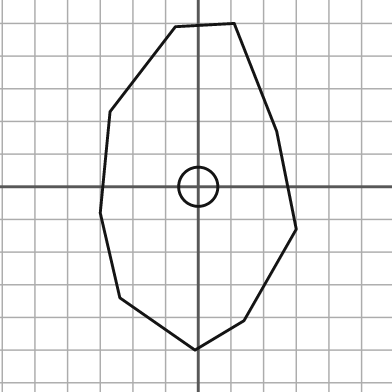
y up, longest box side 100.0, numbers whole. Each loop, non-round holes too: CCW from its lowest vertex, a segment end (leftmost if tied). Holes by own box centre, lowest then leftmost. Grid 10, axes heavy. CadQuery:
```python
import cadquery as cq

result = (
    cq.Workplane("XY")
    .moveTo(-1.0, -50.0)
    .lineTo(14.0, -41.0)
    .lineTo(30.0, -13.0)
    .lineTo(24.0, 17.0)
    .lineTo(11.0, 50.0)
    .lineTo(-7.0, 49.0)
    .lineTo(-27.0, 23.0)
    .lineTo(-30.0, -8.0)
    .lineTo(-24.0, -34.0)
    .close()
    .moveTo(0.0, 0.0)
    .circle(6.0)
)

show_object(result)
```